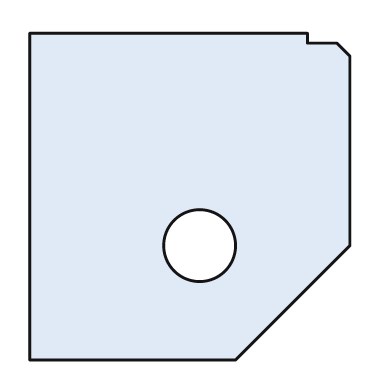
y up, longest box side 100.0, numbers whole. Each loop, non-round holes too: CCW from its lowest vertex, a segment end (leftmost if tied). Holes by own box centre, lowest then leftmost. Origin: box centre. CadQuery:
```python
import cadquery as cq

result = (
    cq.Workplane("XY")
    .moveTo(-49.0, -50.0)
    .lineTo(14.0, -50.0)
    .lineTo(49.0, -15.0)
    .lineTo(49.0, 43.0)
    .lineTo(45.0, 47.0)
    .lineTo(36.0, 47.0)
    .lineTo(36.0, 50.0)
    .lineTo(-49.0, 50.0)
    .close()
    .moveTo(3.0, -15.0)
    .circle(11.0)
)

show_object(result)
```